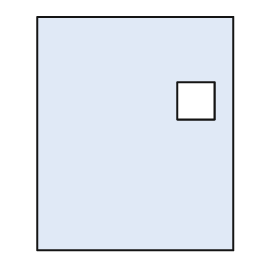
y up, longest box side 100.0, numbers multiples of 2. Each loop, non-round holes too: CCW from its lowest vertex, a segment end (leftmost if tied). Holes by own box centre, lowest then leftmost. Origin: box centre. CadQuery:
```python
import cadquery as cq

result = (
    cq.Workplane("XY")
    .moveTo(-42.0, -50.0)
    .lineTo(42.0, -50.0)
    .lineTo(42.0, 50.0)
    .lineTo(-42.0, 50.0)
    .close()
    .moveTo(18.0, 6.0)
    .lineTo(34.0, 6.0)
    .lineTo(34.0, 22.0)
    .lineTo(18.0, 22.0)
    .close()
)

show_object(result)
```